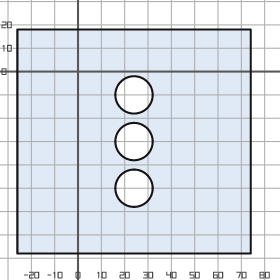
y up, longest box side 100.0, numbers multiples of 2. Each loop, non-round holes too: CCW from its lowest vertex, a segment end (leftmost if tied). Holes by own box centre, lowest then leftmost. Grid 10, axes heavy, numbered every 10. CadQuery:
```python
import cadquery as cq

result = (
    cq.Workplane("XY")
    .moveTo(-26.0, -78.0)
    .lineTo(74.0, -78.0)
    .lineTo(74.0, 18.0)
    .lineTo(-26.0, 18.0)
    .close()
    .moveTo(24.0, -50.0)
    .circle(8.0)
    .moveTo(24.0, -30.0)
    .circle(8.0)
    .moveTo(24.0, -10.0)
    .circle(8.0)
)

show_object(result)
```